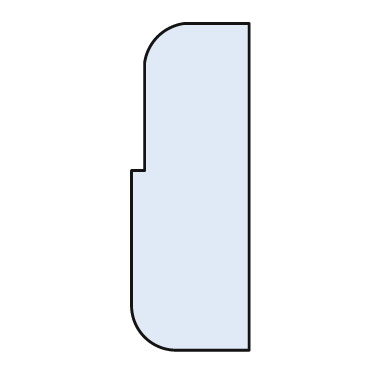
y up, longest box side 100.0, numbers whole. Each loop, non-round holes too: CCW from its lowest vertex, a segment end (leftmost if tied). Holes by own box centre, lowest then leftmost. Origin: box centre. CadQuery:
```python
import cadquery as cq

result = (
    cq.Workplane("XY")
    .moveTo(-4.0, -50.0)
    .lineTo(18.0, -50.0)
    .lineTo(18.0, 50.0)
    .lineTo(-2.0, 50.0)
    .threePointArc((-10.0, 46.0), (-14.0, 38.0))
    .lineTo(-14.0, 5.0)
    .lineTo(-18.0, 5.0)
    .lineTo(-18.0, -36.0)
    .threePointArc((-14.0, -46.0), (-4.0, -50.0))
    .close()
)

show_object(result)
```